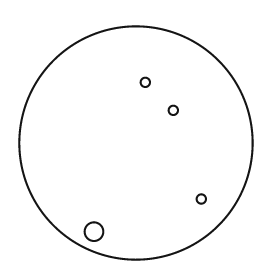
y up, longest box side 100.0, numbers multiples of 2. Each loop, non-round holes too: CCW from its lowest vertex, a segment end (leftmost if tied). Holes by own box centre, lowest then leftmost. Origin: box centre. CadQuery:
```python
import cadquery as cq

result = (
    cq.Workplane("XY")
    .moveTo(0.0, 0.0)
    .circle(50.0)
    .moveTo(-18.0, -38.0)
    .circle(4.0)
    .moveTo(28.0, -24.0)
    .circle(2.0)
    .moveTo(16.0, 14.0)
    .circle(2.0)
    .moveTo(4.0, 26.0)
    .circle(2.0)
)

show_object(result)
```